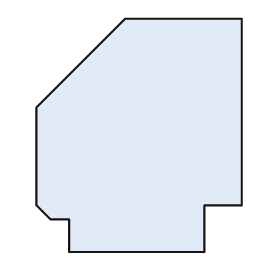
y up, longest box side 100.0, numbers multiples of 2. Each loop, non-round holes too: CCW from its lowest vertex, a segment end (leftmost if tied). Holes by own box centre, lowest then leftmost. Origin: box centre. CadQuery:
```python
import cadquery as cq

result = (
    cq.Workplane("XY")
    .moveTo(-30.0, -50.0)
    .lineTo(28.0, -50.0)
    .lineTo(28.0, -30.0)
    .lineTo(44.0, -30.0)
    .lineTo(44.0, 50.0)
    .lineTo(-6.0, 50.0)
    .lineTo(-44.0, 12.0)
    .lineTo(-44.0, -30.0)
    .lineTo(-38.0, -36.0)
    .lineTo(-30.0, -36.0)
    .close()
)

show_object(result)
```